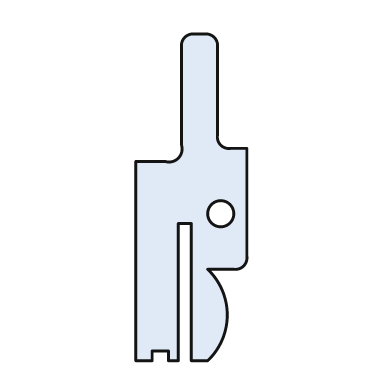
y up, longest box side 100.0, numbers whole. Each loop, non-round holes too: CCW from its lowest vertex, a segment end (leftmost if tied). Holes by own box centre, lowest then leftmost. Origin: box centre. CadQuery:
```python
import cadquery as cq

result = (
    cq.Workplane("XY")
    .moveTo(-17.0, -50.0)
    .lineTo(-12.0, -50.0)
    .lineTo(-12.0, -47.0)
    .lineTo(-7.0, -47.0)
    .lineTo(-7.0, -50.0)
    .lineTo(-4.0, -50.0)
    .lineTo(-4.0, -8.0)
    .lineTo(0.0, -8.0)
    .lineTo(0.0, -50.0)
    .lineTo(5.0, -50.0)
    .threePointArc((11.0, -36.0), (5.0, -22.0))
    .lineTo(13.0, -22.0)
    .threePointArc((16.0, -21.0), (17.0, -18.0))
    .lineTo(17.0, 15.0)
    .lineTo(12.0, 15.0)
    .threePointArc((9.0, 16.0), (8.0, 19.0))
    .lineTo(8.0, 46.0)
    .threePointArc((7.0, 49.0), (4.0, 50.0))
    .lineTo(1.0, 50.0)
    .threePointArc((-2.0, 49.0), (-3.0, 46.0))
    .lineTo(-3.0, 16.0)
    .threePointArc((-4.0, 12.0), (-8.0, 11.0))
    .lineTo(-17.0, 11.0)
    .close()
    .moveTo(9.0, -5.0)
    .circle(4.0)
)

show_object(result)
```